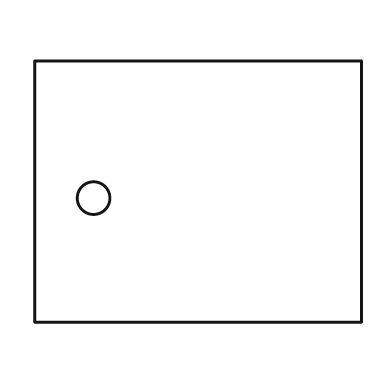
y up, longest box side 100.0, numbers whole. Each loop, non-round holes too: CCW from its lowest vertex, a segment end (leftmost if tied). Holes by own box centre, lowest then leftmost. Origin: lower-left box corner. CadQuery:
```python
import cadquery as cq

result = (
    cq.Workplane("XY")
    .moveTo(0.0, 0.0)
    .lineTo(100.0, 0.0)
    .lineTo(100.0, 80.0)
    .lineTo(0.0, 80.0)
    .close()
    .moveTo(18.0, 38.0)
    .circle(5.0)
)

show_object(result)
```